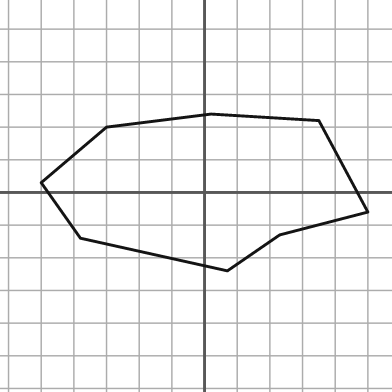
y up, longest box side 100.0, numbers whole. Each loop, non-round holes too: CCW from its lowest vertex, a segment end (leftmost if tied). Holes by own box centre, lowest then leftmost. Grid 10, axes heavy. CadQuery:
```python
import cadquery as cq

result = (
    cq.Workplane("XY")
    .moveTo(7.0, -24.0)
    .lineTo(23.0, -13.0)
    .lineTo(50.0, -6.0)
    .lineTo(35.0, 22.0)
    .lineTo(2.0, 24.0)
    .lineTo(-30.0, 20.0)
    .lineTo(-50.0, 3.0)
    .lineTo(-38.0, -14.0)
    .close()
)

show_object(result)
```